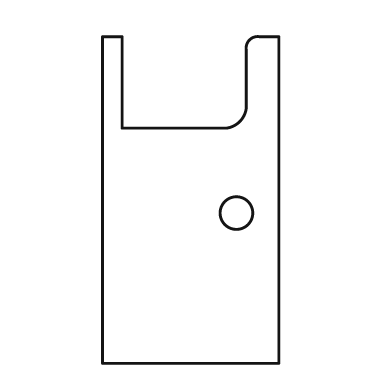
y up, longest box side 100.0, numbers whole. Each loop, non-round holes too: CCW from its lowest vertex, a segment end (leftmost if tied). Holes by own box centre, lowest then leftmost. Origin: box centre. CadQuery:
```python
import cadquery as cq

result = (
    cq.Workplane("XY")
    .moveTo(-27.0, -50.0)
    .lineTo(27.0, -50.0)
    .lineTo(27.0, 50.0)
    .lineTo(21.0, 50.0)
    .threePointArc((18.0, 49.0), (17.0, 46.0))
    .lineTo(17.0, 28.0)
    .threePointArc((15.0, 24.0), (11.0, 22.0))
    .lineTo(-21.0, 22.0)
    .lineTo(-21.0, 50.0)
    .lineTo(-27.0, 50.0)
    .close()
    .moveTo(14.0, -4.0)
    .circle(5.0)
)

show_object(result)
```